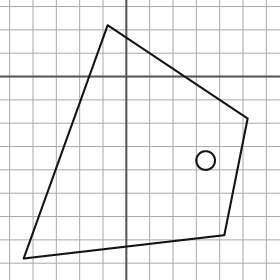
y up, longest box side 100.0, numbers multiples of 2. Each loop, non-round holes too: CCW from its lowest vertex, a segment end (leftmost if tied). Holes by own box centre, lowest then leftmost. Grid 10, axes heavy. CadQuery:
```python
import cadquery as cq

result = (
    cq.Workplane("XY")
    .moveTo(-44.0, -78.0)
    .lineTo(42.0, -68.0)
    .lineTo(52.0, -18.0)
    .lineTo(-8.0, 22.0)
    .close()
    .moveTo(34.0, -36.0)
    .circle(4.0)
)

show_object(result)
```